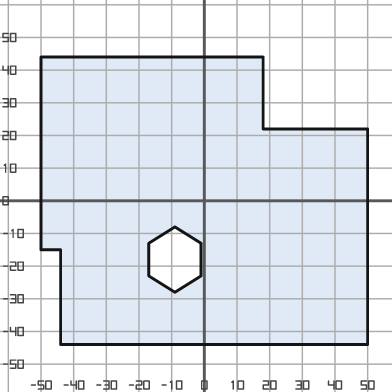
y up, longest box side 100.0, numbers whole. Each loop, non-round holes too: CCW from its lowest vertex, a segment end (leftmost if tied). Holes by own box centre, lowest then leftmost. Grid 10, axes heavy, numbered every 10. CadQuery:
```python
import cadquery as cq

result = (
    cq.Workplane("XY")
    .moveTo(-44.0, -44.0)
    .lineTo(50.0, -44.0)
    .lineTo(50.0, 22.0)
    .lineTo(18.0, 22.0)
    .lineTo(18.0, 44.0)
    .lineTo(-50.0, 44.0)
    .lineTo(-50.0, -15.0)
    .lineTo(-44.0, -15.0)
    .close()
    .moveTo(-9.0, -28.0)
    .lineTo(-1.0, -23.0)
    .lineTo(-1.0, -13.0)
    .lineTo(-9.0, -8.0)
    .lineTo(-17.0, -13.0)
    .lineTo(-17.0, -23.0)
    .close()
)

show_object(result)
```